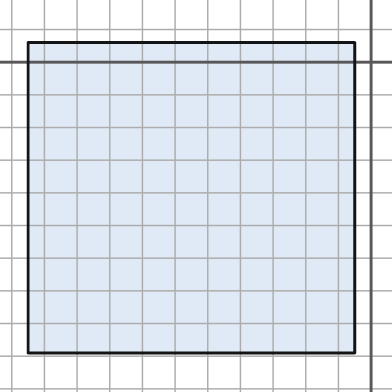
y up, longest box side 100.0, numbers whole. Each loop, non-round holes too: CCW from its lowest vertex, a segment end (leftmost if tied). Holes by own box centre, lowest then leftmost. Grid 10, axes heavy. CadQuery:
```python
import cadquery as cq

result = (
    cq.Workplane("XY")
    .moveTo(-105.0, -89.0)
    .lineTo(-5.0, -89.0)
    .lineTo(-5.0, 6.0)
    .lineTo(-105.0, 6.0)
    .close()
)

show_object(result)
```